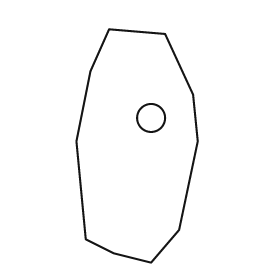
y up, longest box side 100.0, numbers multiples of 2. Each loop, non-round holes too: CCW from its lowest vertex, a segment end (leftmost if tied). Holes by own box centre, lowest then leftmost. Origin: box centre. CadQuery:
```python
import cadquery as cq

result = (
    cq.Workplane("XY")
    .moveTo(6.0, -50.0)
    .lineTo(18.0, -36.0)
    .lineTo(26.0, 2.0)
    .lineTo(24.0, 22.0)
    .lineTo(12.0, 48.0)
    .lineTo(-12.0, 50.0)
    .lineTo(-20.0, 32.0)
    .lineTo(-26.0, 2.0)
    .lineTo(-22.0, -40.0)
    .lineTo(-10.0, -46.0)
    .close()
    .moveTo(6.0, 12.0)
    .circle(6.0)
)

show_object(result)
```